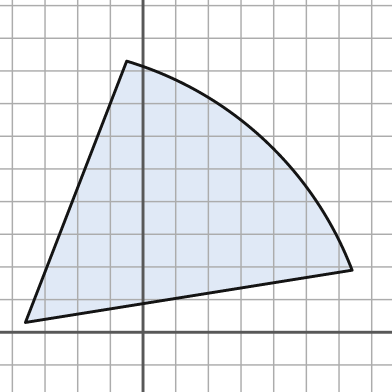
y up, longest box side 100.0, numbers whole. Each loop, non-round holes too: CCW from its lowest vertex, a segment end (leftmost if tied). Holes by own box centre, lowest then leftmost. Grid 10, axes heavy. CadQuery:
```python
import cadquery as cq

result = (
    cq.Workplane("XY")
    .moveTo(-36.0, 3.0)
    .lineTo(64.0, 19.0)
    .threePointArc((37.0, 59.0), (-5.0, 83.0))
    .close()
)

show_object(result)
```